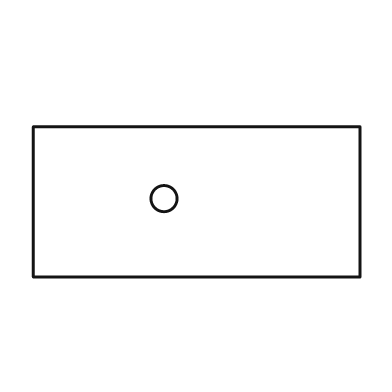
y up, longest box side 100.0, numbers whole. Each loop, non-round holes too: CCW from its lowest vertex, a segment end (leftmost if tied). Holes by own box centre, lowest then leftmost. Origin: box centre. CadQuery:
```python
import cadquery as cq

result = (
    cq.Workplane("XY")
    .moveTo(-50.0, -23.0)
    .lineTo(50.0, -23.0)
    .lineTo(50.0, 23.0)
    .lineTo(-50.0, 23.0)
    .close()
    .moveTo(-10.0, 1.0)
    .circle(4.0)
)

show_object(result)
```